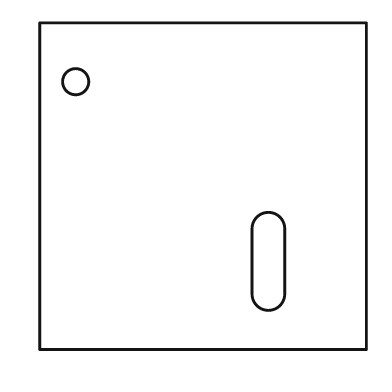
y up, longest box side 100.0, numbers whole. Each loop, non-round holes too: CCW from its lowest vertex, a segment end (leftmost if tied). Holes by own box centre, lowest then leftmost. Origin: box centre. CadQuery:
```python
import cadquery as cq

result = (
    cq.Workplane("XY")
    .moveTo(-50.0, -50.0)
    .lineTo(50.0, -50.0)
    .lineTo(50.0, 50.0)
    .lineTo(-50.0, 50.0)
    .close()
    .moveTo(15.0, -33.0)
    .threePointArc((20.0, -38.0), (25.0, -33.0))
    .lineTo(25.0, -13.0)
    .threePointArc((20.0, -8.0), (15.0, -13.0))
    .close()
    .moveTo(-39.0, 32.0)
    .circle(4.0)
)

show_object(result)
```